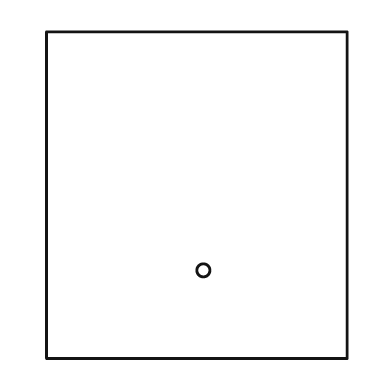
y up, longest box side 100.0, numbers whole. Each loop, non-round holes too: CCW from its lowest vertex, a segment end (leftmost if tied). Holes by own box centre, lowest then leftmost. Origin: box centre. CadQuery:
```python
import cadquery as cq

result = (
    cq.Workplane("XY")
    .moveTo(-46.0, -50.0)
    .lineTo(46.0, -50.0)
    .lineTo(46.0, 50.0)
    .lineTo(-46.0, 50.0)
    .close()
    .moveTo(2.0, -23.0)
    .circle(2.0)
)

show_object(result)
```